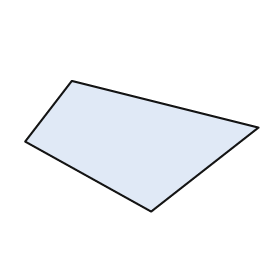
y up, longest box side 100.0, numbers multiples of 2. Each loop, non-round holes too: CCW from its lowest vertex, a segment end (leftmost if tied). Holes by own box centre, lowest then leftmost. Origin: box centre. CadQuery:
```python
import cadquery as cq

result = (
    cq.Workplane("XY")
    .moveTo(4.0, -28.0)
    .lineTo(50.0, 8.0)
    .lineTo(-30.0, 28.0)
    .lineTo(-50.0, 2.0)
    .close()
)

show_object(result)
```